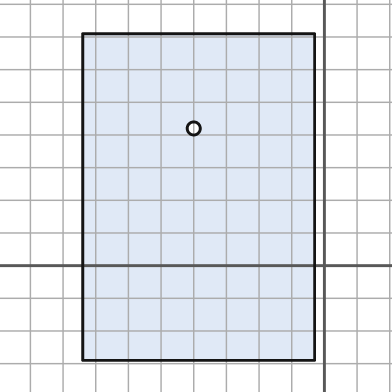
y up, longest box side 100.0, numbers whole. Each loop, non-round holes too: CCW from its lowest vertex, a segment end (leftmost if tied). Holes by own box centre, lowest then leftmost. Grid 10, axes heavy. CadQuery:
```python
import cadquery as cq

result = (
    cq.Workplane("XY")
    .moveTo(-74.0, -29.0)
    .lineTo(-3.0, -29.0)
    .lineTo(-3.0, 71.0)
    .lineTo(-74.0, 71.0)
    .close()
    .moveTo(-40.0, 42.0)
    .circle(2.0)
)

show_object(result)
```